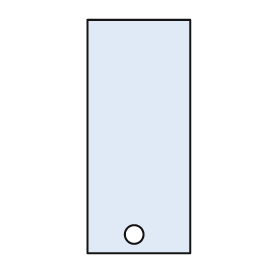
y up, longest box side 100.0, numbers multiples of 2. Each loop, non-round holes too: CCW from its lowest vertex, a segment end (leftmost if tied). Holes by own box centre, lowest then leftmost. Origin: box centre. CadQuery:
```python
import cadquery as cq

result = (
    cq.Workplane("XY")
    .moveTo(-22.0, -50.0)
    .lineTo(22.0, -50.0)
    .lineTo(22.0, 50.0)
    .lineTo(-22.0, 50.0)
    .close()
    .moveTo(-2.0, -42.0)
    .circle(4.0)
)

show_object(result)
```